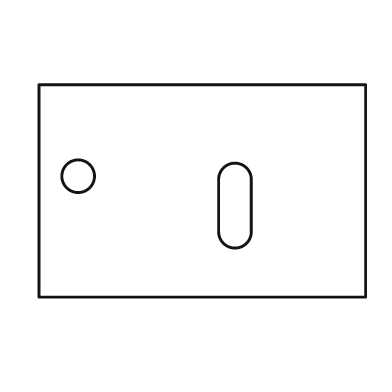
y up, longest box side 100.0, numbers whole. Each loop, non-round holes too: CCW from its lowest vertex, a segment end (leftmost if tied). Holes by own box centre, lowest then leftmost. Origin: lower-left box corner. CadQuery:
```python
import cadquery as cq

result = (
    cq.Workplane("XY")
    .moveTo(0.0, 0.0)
    .lineTo(100.0, 0.0)
    .lineTo(100.0, 65.0)
    .lineTo(0.0, 65.0)
    .close()
    .moveTo(55.0, 20.0)
    .threePointArc((60.0, 15.0), (65.0, 20.0))
    .lineTo(65.0, 36.0)
    .threePointArc((60.0, 41.0), (55.0, 36.0))
    .close()
    .moveTo(12.0, 37.0)
    .circle(5.0)
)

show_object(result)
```